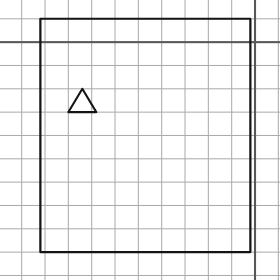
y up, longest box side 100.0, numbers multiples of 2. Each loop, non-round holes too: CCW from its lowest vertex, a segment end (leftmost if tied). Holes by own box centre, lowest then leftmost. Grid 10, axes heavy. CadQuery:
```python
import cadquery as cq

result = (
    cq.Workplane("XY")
    .moveTo(-92.0, -90.0)
    .lineTo(-2.0, -90.0)
    .lineTo(-2.0, 10.0)
    .lineTo(-92.0, 10.0)
    .close()
    .moveTo(-80.0, -30.0)
    .lineTo(-68.0, -30.0)
    .lineTo(-74.0, -20.0)
    .close()
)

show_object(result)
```